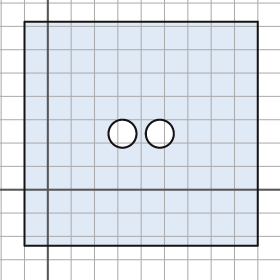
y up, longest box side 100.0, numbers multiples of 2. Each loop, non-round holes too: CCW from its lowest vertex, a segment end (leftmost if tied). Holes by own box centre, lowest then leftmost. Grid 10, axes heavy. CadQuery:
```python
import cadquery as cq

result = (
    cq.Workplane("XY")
    .moveTo(-10.0, -24.0)
    .lineTo(90.0, -24.0)
    .lineTo(90.0, 72.0)
    .lineTo(-10.0, 72.0)
    .close()
    .moveTo(32.0, 24.0)
    .circle(6.0)
    .moveTo(48.0, 24.0)
    .circle(6.0)
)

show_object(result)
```